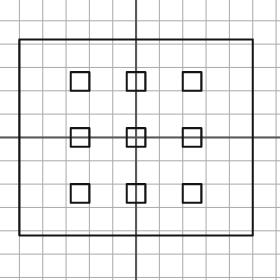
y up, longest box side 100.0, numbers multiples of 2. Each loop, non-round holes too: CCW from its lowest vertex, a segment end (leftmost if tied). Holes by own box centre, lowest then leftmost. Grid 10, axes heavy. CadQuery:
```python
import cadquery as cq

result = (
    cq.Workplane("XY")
    .moveTo(-50.0, -42.0)
    .lineTo(50.0, -42.0)
    .lineTo(50.0, 42.0)
    .lineTo(-50.0, 42.0)
    .close()
    .moveTo(-28.0, -28.0)
    .lineTo(-20.0, -28.0)
    .lineTo(-20.0, -20.0)
    .lineTo(-28.0, -20.0)
    .close()
    .moveTo(-4.0, -28.0)
    .lineTo(4.0, -28.0)
    .lineTo(4.0, -20.0)
    .lineTo(-4.0, -20.0)
    .close()
    .moveTo(20.0, -28.0)
    .lineTo(28.0, -28.0)
    .lineTo(28.0, -20.0)
    .lineTo(20.0, -20.0)
    .close()
    .moveTo(-28.0, -4.0)
    .lineTo(-20.0, -4.0)
    .lineTo(-20.0, 4.0)
    .lineTo(-28.0, 4.0)
    .close()
    .moveTo(-4.0, -4.0)
    .lineTo(4.0, -4.0)
    .lineTo(4.0, 4.0)
    .lineTo(-4.0, 4.0)
    .close()
    .moveTo(20.0, -4.0)
    .lineTo(28.0, -4.0)
    .lineTo(28.0, 4.0)
    .lineTo(20.0, 4.0)
    .close()
    .moveTo(-28.0, 20.0)
    .lineTo(-20.0, 20.0)
    .lineTo(-20.0, 28.0)
    .lineTo(-28.0, 28.0)
    .close()
    .moveTo(-4.0, 20.0)
    .lineTo(4.0, 20.0)
    .lineTo(4.0, 28.0)
    .lineTo(-4.0, 28.0)
    .close()
    .moveTo(20.0, 20.0)
    .lineTo(28.0, 20.0)
    .lineTo(28.0, 28.0)
    .lineTo(20.0, 28.0)
    .close()
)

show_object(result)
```